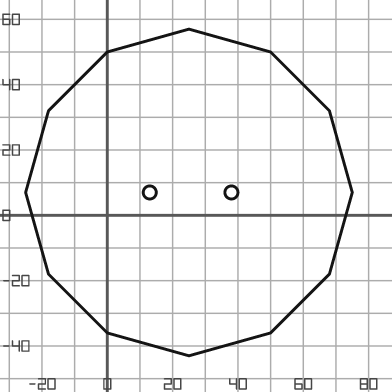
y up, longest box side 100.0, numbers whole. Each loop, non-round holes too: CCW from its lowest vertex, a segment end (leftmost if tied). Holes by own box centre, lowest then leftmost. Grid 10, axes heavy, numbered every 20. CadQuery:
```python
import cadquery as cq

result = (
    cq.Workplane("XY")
    .moveTo(25.0, -43.0)
    .lineTo(50.0, -36.0)
    .lineTo(68.0, -18.0)
    .lineTo(75.0, 7.0)
    .lineTo(68.0, 32.0)
    .lineTo(50.0, 50.0)
    .lineTo(25.0, 57.0)
    .lineTo(0.0, 50.0)
    .lineTo(-18.0, 32.0)
    .lineTo(-25.0, 7.0)
    .lineTo(-18.0, -18.0)
    .lineTo(0.0, -36.0)
    .close()
    .moveTo(13.0, 7.0)
    .circle(2.0)
    .moveTo(38.0, 7.0)
    .circle(2.0)
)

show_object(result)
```